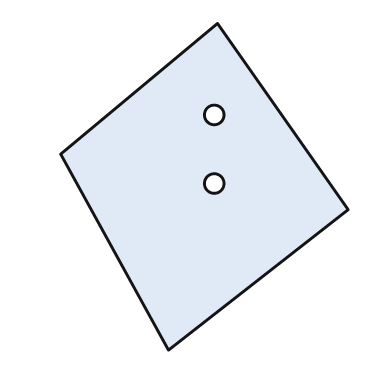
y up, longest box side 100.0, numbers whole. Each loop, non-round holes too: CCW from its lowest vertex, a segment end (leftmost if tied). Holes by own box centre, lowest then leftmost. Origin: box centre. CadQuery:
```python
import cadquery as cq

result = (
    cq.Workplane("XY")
    .moveTo(-11.0, -50.0)
    .lineTo(44.0, -7.0)
    .lineTo(4.0, 50.0)
    .lineTo(-44.0, 10.0)
    .close()
    .moveTo(3.0, 1.0)
    .circle(3.0)
    .moveTo(3.0, 22.0)
    .circle(3.0)
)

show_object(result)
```